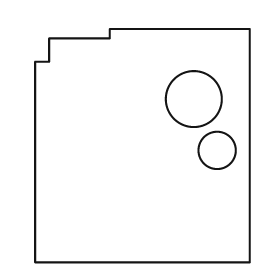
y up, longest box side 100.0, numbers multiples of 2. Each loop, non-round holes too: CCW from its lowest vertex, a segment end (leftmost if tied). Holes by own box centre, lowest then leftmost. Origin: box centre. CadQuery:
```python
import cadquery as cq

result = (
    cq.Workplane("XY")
    .moveTo(-46.0, -50.0)
    .lineTo(46.0, -50.0)
    .lineTo(46.0, 50.0)
    .lineTo(-14.0, 50.0)
    .lineTo(-14.0, 46.0)
    .lineTo(-40.0, 46.0)
    .lineTo(-40.0, 36.0)
    .lineTo(-46.0, 36.0)
    .close()
    .moveTo(32.0, -2.0)
    .circle(8.0)
    .moveTo(22.0, 20.0)
    .circle(12.0)
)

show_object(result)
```